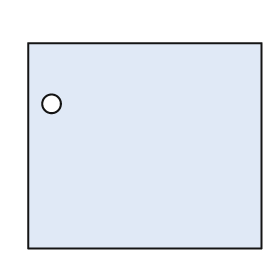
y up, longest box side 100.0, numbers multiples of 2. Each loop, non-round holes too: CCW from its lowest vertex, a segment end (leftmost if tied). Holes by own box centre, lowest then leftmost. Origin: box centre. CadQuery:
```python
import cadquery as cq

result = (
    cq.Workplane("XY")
    .moveTo(-50.0, -44.0)
    .lineTo(50.0, -44.0)
    .lineTo(50.0, 44.0)
    .lineTo(-50.0, 44.0)
    .close()
    .moveTo(-40.0, 18.0)
    .circle(4.0)
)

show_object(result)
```